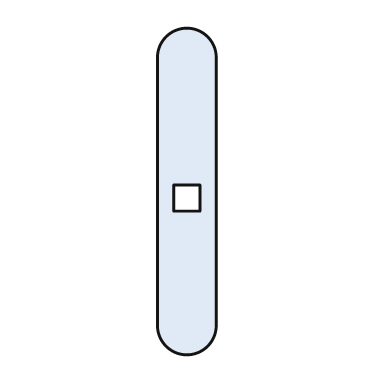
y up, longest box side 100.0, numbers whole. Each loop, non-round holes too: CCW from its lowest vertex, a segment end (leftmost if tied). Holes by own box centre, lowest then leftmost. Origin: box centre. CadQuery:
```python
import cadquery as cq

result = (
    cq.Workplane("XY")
    .moveTo(-9.0, -41.0)
    .threePointArc((0.0, -50.0), (9.0, -41.0))
    .lineTo(9.0, 41.0)
    .threePointArc((0.0, 50.0), (-9.0, 41.0))
    .close()
    .moveTo(-4.0, -6.0)
    .lineTo(4.0, -6.0)
    .lineTo(4.0, 2.0)
    .lineTo(-4.0, 2.0)
    .close()
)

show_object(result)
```